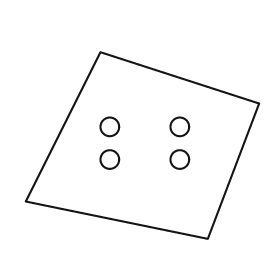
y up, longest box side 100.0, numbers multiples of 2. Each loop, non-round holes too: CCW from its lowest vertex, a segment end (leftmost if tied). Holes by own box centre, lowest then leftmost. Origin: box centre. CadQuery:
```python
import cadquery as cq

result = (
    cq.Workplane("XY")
    .moveTo(28.0, -40.0)
    .lineTo(50.0, 18.0)
    .lineTo(-18.0, 40.0)
    .lineTo(-50.0, -24.0)
    .close()
    .moveTo(-14.0, -6.0)
    .circle(4.0)
    .moveTo(16.0, -6.0)
    .circle(4.0)
    .moveTo(-14.0, 8.0)
    .circle(4.0)
    .moveTo(16.0, 8.0)
    .circle(4.0)
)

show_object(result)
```